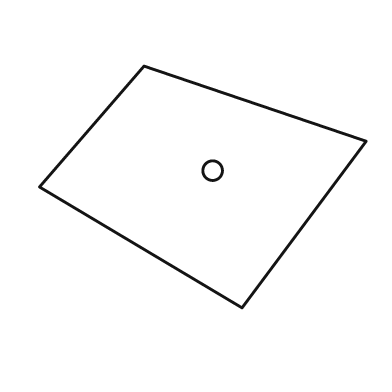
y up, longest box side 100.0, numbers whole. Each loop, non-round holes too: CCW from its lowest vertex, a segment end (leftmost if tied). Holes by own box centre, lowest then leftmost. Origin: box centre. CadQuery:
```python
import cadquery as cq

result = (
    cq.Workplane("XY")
    .moveTo(12.0, -37.0)
    .lineTo(50.0, 14.0)
    .lineTo(-18.0, 37.0)
    .lineTo(-50.0, 0.0)
    .close()
    .moveTo(3.0, 5.0)
    .circle(3.0)
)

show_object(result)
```